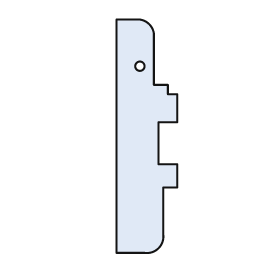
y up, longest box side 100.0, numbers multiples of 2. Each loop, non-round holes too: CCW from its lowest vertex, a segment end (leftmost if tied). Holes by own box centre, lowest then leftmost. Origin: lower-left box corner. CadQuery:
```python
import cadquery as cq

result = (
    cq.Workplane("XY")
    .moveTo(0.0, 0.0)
    .lineTo(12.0, 0.0)
    .threePointArc((18.0, 2.0), (20.0, 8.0))
    .lineTo(20.0, 28.0)
    .lineTo(26.0, 28.0)
    .lineTo(26.0, 38.0)
    .lineTo(18.0, 38.0)
    .lineTo(18.0, 56.0)
    .lineTo(26.0, 56.0)
    .lineTo(26.0, 68.0)
    .lineTo(22.0, 68.0)
    .lineTo(22.0, 72.0)
    .lineTo(16.0, 72.0)
    .lineTo(16.0, 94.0)
    .threePointArc((14.0, 98.0), (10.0, 100.0))
    .lineTo(0.0, 100.0)
    .close()
    .moveTo(10.0, 80.0)
    .circle(2.0)
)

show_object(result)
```